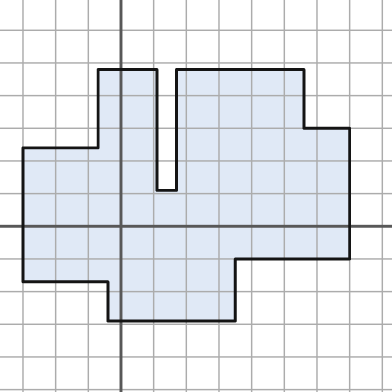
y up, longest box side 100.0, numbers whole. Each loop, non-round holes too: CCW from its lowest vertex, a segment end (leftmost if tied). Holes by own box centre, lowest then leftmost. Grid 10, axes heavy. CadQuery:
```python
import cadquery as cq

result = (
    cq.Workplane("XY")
    .moveTo(-4.0, -29.0)
    .lineTo(35.0, -29.0)
    .lineTo(35.0, -10.0)
    .lineTo(70.0, -10.0)
    .lineTo(70.0, 30.0)
    .lineTo(56.0, 30.0)
    .lineTo(56.0, 48.0)
    .lineTo(17.0, 48.0)
    .lineTo(17.0, 11.0)
    .lineTo(11.0, 11.0)
    .lineTo(11.0, 48.0)
    .lineTo(-7.0, 48.0)
    .lineTo(-7.0, 24.0)
    .lineTo(-30.0, 24.0)
    .lineTo(-30.0, -17.0)
    .lineTo(-4.0, -17.0)
    .close()
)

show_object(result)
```